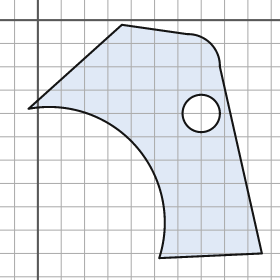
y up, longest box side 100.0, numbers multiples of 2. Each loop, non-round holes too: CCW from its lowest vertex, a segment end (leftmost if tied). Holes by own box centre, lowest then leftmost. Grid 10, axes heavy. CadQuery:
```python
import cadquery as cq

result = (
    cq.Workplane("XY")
    .moveTo(52.0, -102.0)
    .lineTo(96.0, -100.0)
    .lineTo(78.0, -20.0)
    .threePointArc((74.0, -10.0), (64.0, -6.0))
    .lineTo(36.0, -2.0)
    .lineTo(-4.0, -38.0)
    .threePointArc((42.0, -54.0), (52.0, -102.0))
    .close()
    .moveTo(70.0, -40.0)
    .circle(8.0)
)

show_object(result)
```